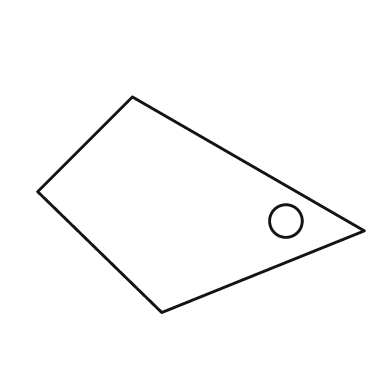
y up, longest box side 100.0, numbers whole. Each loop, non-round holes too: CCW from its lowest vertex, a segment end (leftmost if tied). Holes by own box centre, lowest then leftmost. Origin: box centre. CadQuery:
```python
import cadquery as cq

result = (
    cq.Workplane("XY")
    .moveTo(-12.0, -33.0)
    .lineTo(50.0, -8.0)
    .lineTo(-21.0, 33.0)
    .lineTo(-50.0, 4.0)
    .close()
    .moveTo(26.0, -5.0)
    .circle(5.0)
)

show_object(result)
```